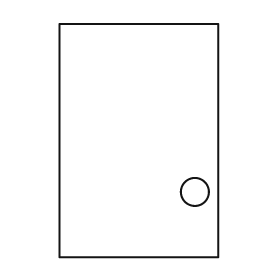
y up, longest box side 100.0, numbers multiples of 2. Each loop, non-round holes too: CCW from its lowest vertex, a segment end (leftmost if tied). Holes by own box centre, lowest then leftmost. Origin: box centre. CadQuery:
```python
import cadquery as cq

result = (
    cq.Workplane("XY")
    .moveTo(-34.0, -50.0)
    .lineTo(34.0, -50.0)
    .lineTo(34.0, 50.0)
    .lineTo(-34.0, 50.0)
    .close()
    .moveTo(24.0, -22.0)
    .circle(6.0)
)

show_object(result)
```